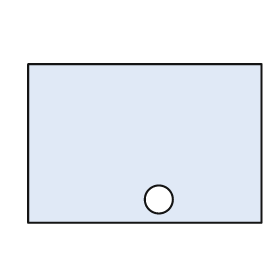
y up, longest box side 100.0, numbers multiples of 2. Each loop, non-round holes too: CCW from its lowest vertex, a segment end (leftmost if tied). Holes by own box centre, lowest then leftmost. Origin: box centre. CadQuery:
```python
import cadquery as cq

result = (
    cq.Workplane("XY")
    .moveTo(-50.0, -34.0)
    .lineTo(50.0, -34.0)
    .lineTo(50.0, 34.0)
    .lineTo(-50.0, 34.0)
    .close()
    .moveTo(6.0, -24.0)
    .circle(6.0)
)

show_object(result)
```